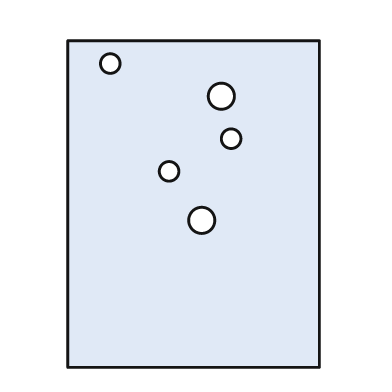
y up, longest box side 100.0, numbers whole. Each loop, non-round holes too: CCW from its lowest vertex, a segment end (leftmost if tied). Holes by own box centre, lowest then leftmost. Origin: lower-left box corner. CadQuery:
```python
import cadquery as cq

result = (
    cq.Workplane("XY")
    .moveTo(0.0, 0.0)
    .lineTo(77.0, 0.0)
    .lineTo(77.0, 100.0)
    .lineTo(0.0, 100.0)
    .close()
    .moveTo(41.0, 45.0)
    .circle(4.0)
    .moveTo(31.0, 60.0)
    .circle(3.0)
    .moveTo(50.0, 70.0)
    .circle(3.0)
    .moveTo(47.0, 83.0)
    .circle(4.0)
    .moveTo(13.0, 93.0)
    .circle(3.0)
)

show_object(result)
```